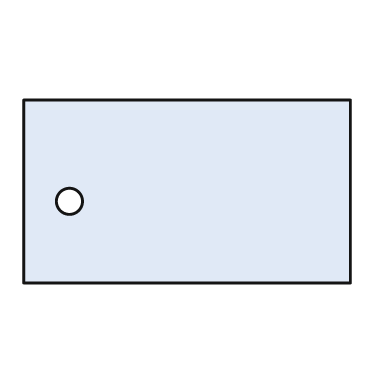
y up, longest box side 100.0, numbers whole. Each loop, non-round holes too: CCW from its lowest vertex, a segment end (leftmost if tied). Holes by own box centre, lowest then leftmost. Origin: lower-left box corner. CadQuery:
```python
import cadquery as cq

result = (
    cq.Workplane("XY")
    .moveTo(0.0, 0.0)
    .lineTo(100.0, 0.0)
    .lineTo(100.0, 56.0)
    .lineTo(0.0, 56.0)
    .close()
    .moveTo(14.0, 25.0)
    .circle(4.0)
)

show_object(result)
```